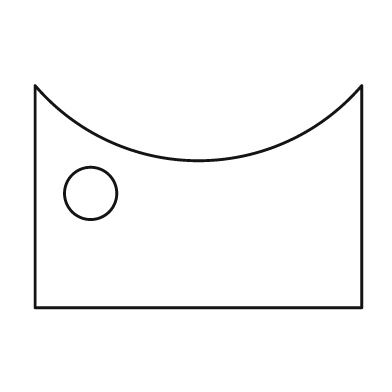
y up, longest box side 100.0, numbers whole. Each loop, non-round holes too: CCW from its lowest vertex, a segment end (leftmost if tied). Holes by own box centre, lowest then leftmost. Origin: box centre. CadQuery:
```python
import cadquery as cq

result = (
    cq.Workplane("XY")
    .moveTo(-50.0, -34.0)
    .lineTo(50.0, -34.0)
    .lineTo(50.0, 34.0)
    .threePointArc((0.0, 11.0), (-50.0, 34.0))
    .close()
    .moveTo(-33.0, 1.0)
    .circle(8.0)
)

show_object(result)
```